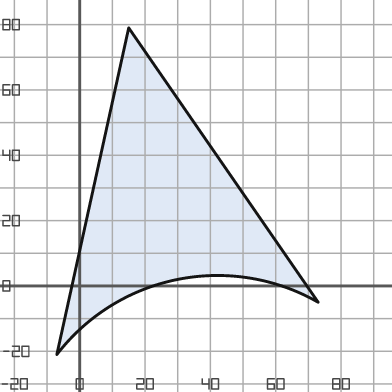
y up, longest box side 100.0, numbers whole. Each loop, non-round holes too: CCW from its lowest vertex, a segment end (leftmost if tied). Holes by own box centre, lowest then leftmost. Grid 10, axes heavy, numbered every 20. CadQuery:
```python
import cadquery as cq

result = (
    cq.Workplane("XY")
    .moveTo(-7.0, -21.0)
    .threePointArc((30.0, 2.0), (73.0, -5.0))
    .lineTo(15.0, 79.0)
    .close()
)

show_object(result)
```